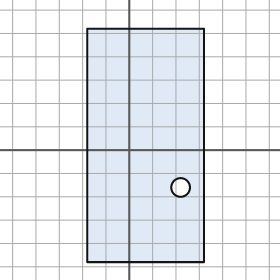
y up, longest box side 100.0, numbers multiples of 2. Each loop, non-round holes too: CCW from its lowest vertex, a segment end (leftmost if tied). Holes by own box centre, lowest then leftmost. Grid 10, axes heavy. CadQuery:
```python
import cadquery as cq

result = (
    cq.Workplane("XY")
    .moveTo(-18.0, -48.0)
    .lineTo(32.0, -48.0)
    .lineTo(32.0, 52.0)
    .lineTo(-18.0, 52.0)
    .close()
    .moveTo(22.0, -16.0)
    .circle(4.0)
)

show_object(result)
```